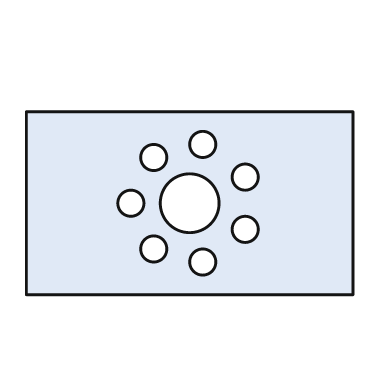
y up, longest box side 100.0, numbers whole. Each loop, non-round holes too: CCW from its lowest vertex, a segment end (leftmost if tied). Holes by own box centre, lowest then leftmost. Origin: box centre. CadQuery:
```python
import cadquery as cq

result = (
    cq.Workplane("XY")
    .moveTo(-50.0, -28.0)
    .lineTo(50.0, -28.0)
    .lineTo(50.0, 28.0)
    .lineTo(-50.0, 28.0)
    .close()
    .moveTo(4.0, -18.0)
    .circle(4.0)
    .moveTo(-11.0, -14.0)
    .circle(4.0)
    .moveTo(17.0, -8.0)
    .circle(4.0)
    .moveTo(-18.0, 0.0)
    .circle(4.0)
    .moveTo(0.0, 0.0)
    .circle(9.0)
    .moveTo(17.0, 8.0)
    .circle(4.0)
    .moveTo(-11.0, 14.0)
    .circle(4.0)
    .moveTo(4.0, 18.0)
    .circle(4.0)
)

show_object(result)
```